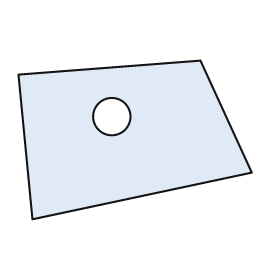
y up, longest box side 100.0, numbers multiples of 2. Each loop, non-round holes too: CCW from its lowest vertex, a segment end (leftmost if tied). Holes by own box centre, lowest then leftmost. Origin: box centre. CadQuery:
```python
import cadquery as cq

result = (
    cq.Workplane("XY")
    .moveTo(-44.0, -34.0)
    .lineTo(50.0, -14.0)
    .lineTo(28.0, 34.0)
    .lineTo(-50.0, 28.0)
    .close()
    .moveTo(-10.0, 10.0)
    .circle(8.0)
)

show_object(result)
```